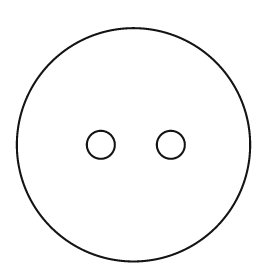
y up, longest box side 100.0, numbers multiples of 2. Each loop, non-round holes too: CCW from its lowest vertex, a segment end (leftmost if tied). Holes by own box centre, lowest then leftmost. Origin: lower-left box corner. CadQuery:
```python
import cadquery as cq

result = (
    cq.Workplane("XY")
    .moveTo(50.0, 50.0)
    .circle(50.0)
    .moveTo(36.0, 50.0)
    .circle(6.0)
    .moveTo(66.0, 50.0)
    .circle(6.0)
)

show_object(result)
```